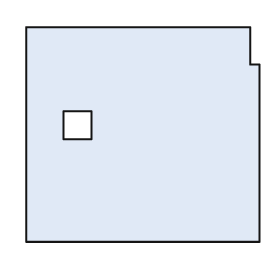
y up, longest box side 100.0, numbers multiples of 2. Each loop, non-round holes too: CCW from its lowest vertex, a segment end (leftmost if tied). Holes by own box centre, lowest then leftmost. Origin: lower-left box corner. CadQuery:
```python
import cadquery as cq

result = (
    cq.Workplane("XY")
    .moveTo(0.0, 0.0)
    .lineTo(100.0, 0.0)
    .lineTo(100.0, 76.0)
    .lineTo(96.0, 76.0)
    .lineTo(96.0, 92.0)
    .lineTo(0.0, 92.0)
    .close()
    .moveTo(16.0, 44.0)
    .lineTo(28.0, 44.0)
    .lineTo(28.0, 56.0)
    .lineTo(16.0, 56.0)
    .close()
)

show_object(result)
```